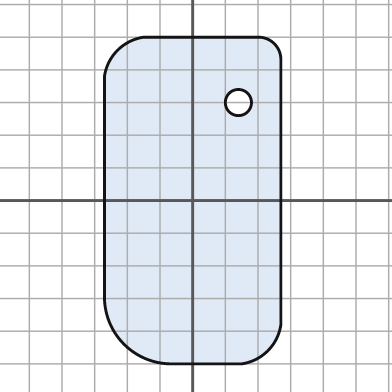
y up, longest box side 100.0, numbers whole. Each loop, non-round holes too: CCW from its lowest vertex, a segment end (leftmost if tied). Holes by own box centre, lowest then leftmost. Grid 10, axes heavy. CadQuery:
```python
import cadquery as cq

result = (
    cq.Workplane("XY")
    .moveTo(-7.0, -50.0)
    .lineTo(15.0, -50.0)
    .threePointArc((23.0, -46.0), (27.0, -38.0))
    .lineTo(27.0, 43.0)
    .threePointArc((25.0, 48.0), (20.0, 50.0))
    .lineTo(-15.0, 50.0)
    .threePointArc((-23.0, 46.0), (-27.0, 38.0))
    .lineTo(-27.0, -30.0)
    .threePointArc((-21.0, -44.0), (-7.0, -50.0))
    .close()
    .moveTo(14.0, 30.0)
    .circle(4.0)
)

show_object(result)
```